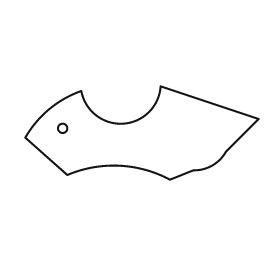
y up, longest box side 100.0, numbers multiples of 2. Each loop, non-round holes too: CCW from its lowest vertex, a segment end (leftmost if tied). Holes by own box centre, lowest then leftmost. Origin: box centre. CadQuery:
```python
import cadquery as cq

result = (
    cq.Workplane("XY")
    .moveTo(12.0, -20.0)
    .lineTo(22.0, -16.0)
    .threePointArc((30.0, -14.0), (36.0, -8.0))
    .lineTo(50.0, 6.0)
    .lineTo(8.0, 20.0)
    .threePointArc((-8.0, 4.0), (-26.0, 18.0))
    .threePointArc((-40.0, 10.0), (-50.0, -2.0))
    .lineTo(-32.0, -18.0)
    .threePointArc((-10.0, -14.0), (12.0, -20.0))
    .close()
    .moveTo(-34.0, 2.0)
    .circle(2.0)
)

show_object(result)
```